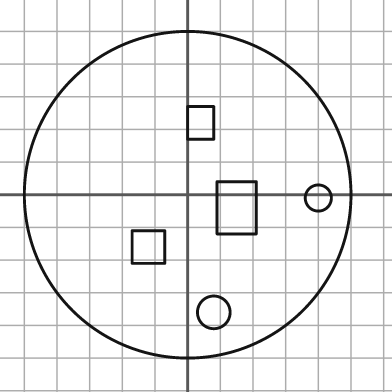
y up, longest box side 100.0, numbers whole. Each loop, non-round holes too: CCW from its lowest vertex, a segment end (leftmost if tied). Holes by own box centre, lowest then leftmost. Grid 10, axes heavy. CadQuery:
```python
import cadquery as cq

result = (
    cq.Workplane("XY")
    .moveTo(0.0, 0.0)
    .circle(50.0)
    .moveTo(8.0, -36.0)
    .circle(5.0)
    .moveTo(-17.0, -21.0)
    .lineTo(-7.0, -21.0)
    .lineTo(-7.0, -11.0)
    .lineTo(-17.0, -11.0)
    .close()
    .moveTo(9.0, -12.0)
    .lineTo(21.0, -12.0)
    .lineTo(21.0, 4.0)
    .lineTo(9.0, 4.0)
    .close()
    .moveTo(40.0, -1.0)
    .circle(4.0)
    .moveTo(0.0, 17.0)
    .lineTo(8.0, 17.0)
    .lineTo(8.0, 27.0)
    .lineTo(0.0, 27.0)
    .close()
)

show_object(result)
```